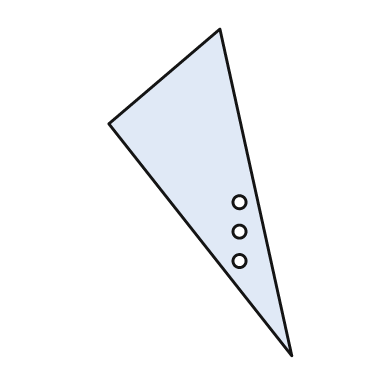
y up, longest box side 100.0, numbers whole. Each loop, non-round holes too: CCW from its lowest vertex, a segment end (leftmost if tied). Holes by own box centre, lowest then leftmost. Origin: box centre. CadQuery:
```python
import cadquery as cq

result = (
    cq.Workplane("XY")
    .moveTo(28.0, -50.0)
    .lineTo(6.0, 50.0)
    .lineTo(-28.0, 21.0)
    .close()
    .moveTo(12.0, -21.0)
    .circle(2.0)
    .moveTo(12.0, -12.0)
    .circle(2.0)
    .moveTo(12.0, -3.0)
    .circle(2.0)
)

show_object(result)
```